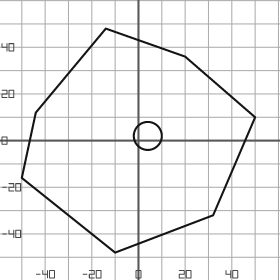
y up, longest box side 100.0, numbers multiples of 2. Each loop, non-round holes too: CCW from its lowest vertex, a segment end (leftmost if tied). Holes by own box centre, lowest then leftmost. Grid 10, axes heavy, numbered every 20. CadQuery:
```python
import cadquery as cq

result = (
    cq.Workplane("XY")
    .moveTo(-10.0, -48.0)
    .lineTo(32.0, -32.0)
    .lineTo(50.0, 10.0)
    .lineTo(20.0, 36.0)
    .lineTo(-14.0, 48.0)
    .lineTo(-44.0, 12.0)
    .lineTo(-50.0, -16.0)
    .close()
    .moveTo(4.0, 2.0)
    .circle(6.0)
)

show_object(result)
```